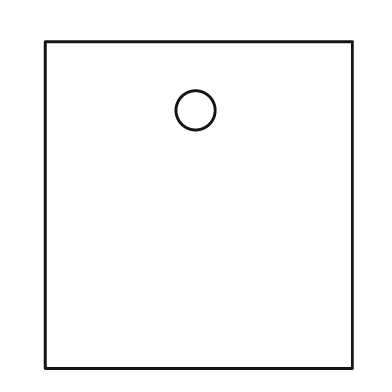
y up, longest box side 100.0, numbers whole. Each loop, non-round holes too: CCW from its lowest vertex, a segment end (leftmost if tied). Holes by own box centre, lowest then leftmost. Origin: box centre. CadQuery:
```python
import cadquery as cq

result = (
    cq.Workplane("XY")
    .moveTo(-47.0, -50.0)
    .lineTo(47.0, -50.0)
    .lineTo(47.0, 50.0)
    .lineTo(-47.0, 50.0)
    .close()
    .moveTo(-1.0, 29.0)
    .circle(6.0)
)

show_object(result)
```